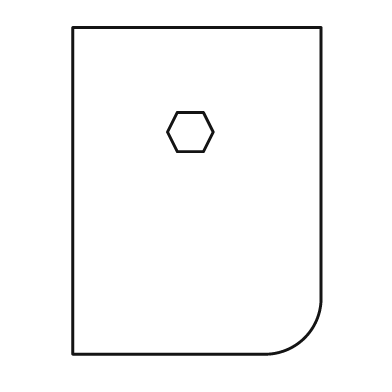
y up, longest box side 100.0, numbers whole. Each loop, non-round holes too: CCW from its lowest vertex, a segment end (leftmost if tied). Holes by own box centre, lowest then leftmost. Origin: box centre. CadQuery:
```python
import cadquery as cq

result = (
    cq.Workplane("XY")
    .moveTo(-38.0, -50.0)
    .lineTo(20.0, -50.0)
    .threePointArc((33.0, -45.0), (38.0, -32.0))
    .lineTo(38.0, 50.0)
    .lineTo(-38.0, 50.0)
    .close()
    .moveTo(-6.0, 12.0)
    .lineTo(2.0, 12.0)
    .lineTo(5.0, 18.0)
    .lineTo(2.0, 24.0)
    .lineTo(-6.0, 24.0)
    .lineTo(-9.0, 18.0)
    .close()
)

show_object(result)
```